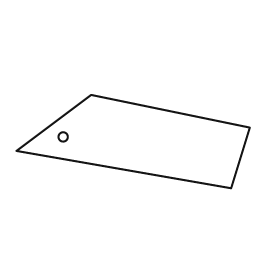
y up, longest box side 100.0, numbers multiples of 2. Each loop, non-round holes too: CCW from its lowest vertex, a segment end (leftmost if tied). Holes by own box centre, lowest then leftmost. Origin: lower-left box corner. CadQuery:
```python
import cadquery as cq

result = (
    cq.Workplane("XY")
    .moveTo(92.0, 0.0)
    .lineTo(100.0, 26.0)
    .lineTo(32.0, 40.0)
    .lineTo(0.0, 16.0)
    .close()
    .moveTo(20.0, 22.0)
    .circle(2.0)
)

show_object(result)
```